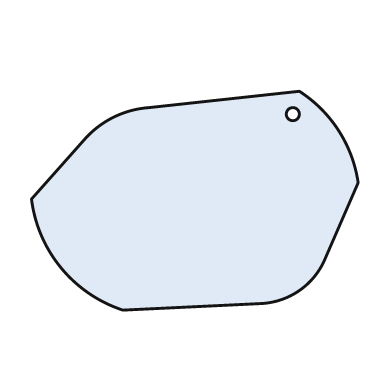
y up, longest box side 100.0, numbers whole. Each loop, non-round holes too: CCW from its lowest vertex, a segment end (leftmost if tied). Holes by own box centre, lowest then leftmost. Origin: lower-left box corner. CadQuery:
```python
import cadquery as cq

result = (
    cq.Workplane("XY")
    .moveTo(28.0, 0.0)
    .lineTo(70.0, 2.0)
    .threePointArc((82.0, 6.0), (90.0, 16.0))
    .lineTo(100.0, 39.0)
    .threePointArc((94.0, 55.0), (82.0, 67.0))
    .lineTo(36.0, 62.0)
    .threePointArc((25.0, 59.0), (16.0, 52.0))
    .lineTo(0.0, 34.0)
    .threePointArc((9.0, 13.0), (28.0, 0.0))
    .close()
    .moveTo(80.0, 60.0)
    .circle(2.0)
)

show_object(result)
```